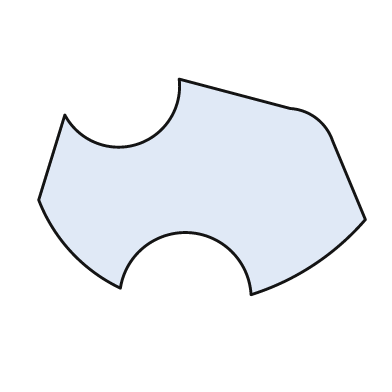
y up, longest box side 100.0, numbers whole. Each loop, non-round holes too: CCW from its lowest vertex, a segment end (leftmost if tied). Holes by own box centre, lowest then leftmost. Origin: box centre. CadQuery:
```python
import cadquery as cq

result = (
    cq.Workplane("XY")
    .moveTo(15.0, -33.0)
    .threePointArc((34.0, -24.0), (50.0, -10.0))
    .lineTo(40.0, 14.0)
    .threePointArc((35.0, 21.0), (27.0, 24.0))
    .lineTo(-7.0, 33.0)
    .threePointArc((-20.0, 13.0), (-42.0, 22.0))
    .lineTo(-50.0, -4.0)
    .threePointArc((-40.0, -20.0), (-25.0, -31.0))
    .threePointArc((-4.0, -14.0), (15.0, -33.0))
    .close()
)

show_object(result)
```